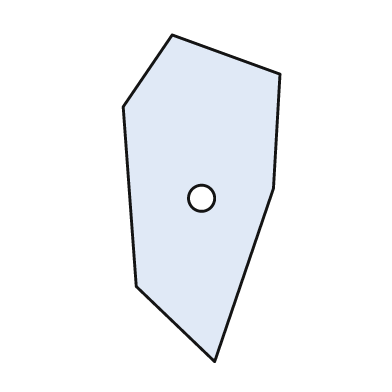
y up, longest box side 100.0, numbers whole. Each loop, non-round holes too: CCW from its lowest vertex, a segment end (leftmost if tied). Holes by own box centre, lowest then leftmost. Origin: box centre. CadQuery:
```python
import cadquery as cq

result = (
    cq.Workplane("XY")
    .moveTo(4.0, -50.0)
    .lineTo(22.0, 3.0)
    .lineTo(24.0, 38.0)
    .lineTo(-9.0, 50.0)
    .lineTo(-24.0, 28.0)
    .lineTo(-20.0, -27.0)
    .close()
    .moveTo(0.0, 0.0)
    .circle(4.0)
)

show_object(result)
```